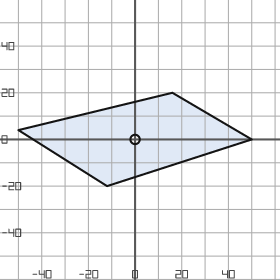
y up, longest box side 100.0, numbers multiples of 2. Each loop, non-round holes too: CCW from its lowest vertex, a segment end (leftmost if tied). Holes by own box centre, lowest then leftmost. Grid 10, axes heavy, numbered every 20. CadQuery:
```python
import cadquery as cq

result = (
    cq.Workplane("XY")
    .moveTo(-12.0, -20.0)
    .lineTo(50.0, 0.0)
    .lineTo(16.0, 20.0)
    .lineTo(-50.0, 4.0)
    .close()
    .moveTo(0.0, 0.0)
    .circle(2.0)
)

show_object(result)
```